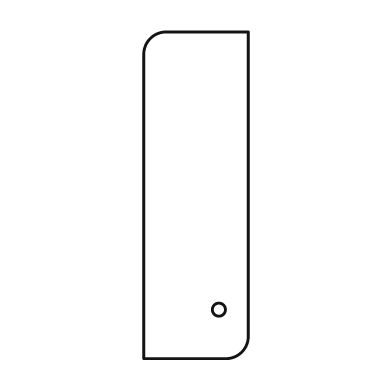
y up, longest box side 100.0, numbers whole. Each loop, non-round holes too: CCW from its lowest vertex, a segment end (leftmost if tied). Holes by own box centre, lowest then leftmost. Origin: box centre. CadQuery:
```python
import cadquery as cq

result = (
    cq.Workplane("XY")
    .moveTo(-16.0, -50.0)
    .lineTo(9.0, -50.0)
    .threePointArc((14.0, -48.0), (16.0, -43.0))
    .lineTo(16.0, 50.0)
    .lineTo(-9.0, 50.0)
    .threePointArc((-14.0, 48.0), (-16.0, 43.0))
    .close()
    .moveTo(7.0, -35.0)
    .circle(2.0)
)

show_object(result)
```